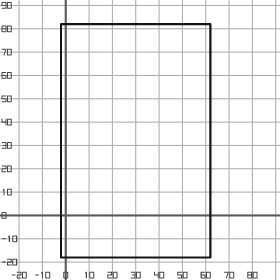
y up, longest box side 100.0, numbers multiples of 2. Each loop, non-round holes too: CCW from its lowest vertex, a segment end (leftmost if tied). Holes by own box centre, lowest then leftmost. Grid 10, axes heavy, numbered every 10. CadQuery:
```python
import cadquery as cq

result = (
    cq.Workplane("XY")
    .moveTo(-2.0, -18.0)
    .lineTo(62.0, -18.0)
    .lineTo(62.0, 82.0)
    .lineTo(-2.0, 82.0)
    .close()
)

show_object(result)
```